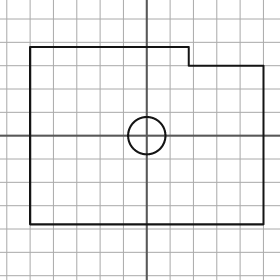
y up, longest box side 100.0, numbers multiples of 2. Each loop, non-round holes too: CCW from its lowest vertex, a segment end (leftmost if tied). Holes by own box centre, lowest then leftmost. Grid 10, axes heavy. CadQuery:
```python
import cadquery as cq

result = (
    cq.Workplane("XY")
    .moveTo(-50.0, -38.0)
    .lineTo(50.0, -38.0)
    .lineTo(50.0, 30.0)
    .lineTo(18.0, 30.0)
    .lineTo(18.0, 38.0)
    .lineTo(-50.0, 38.0)
    .close()
    .moveTo(0.0, 0.0)
    .circle(8.0)
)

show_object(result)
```